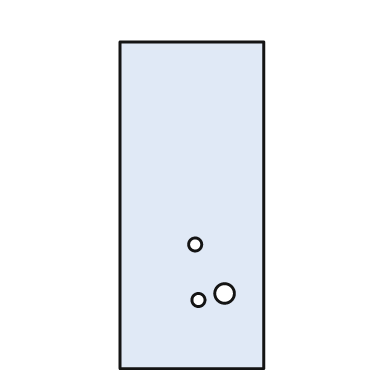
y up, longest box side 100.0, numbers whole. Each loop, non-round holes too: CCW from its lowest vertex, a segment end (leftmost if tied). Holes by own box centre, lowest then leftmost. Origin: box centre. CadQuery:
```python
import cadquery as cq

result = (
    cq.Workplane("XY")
    .moveTo(-22.0, -50.0)
    .lineTo(22.0, -50.0)
    .lineTo(22.0, 50.0)
    .lineTo(-22.0, 50.0)
    .close()
    .moveTo(2.0, -29.0)
    .circle(2.0)
    .moveTo(10.0, -27.0)
    .circle(3.0)
    .moveTo(1.0, -12.0)
    .circle(2.0)
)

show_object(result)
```